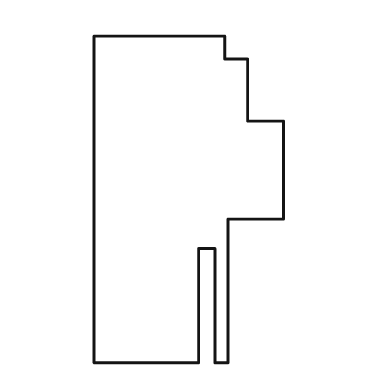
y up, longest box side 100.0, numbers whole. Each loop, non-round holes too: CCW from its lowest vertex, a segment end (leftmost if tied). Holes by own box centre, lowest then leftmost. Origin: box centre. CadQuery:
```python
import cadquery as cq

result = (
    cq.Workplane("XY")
    .moveTo(-29.0, -50.0)
    .lineTo(3.0, -50.0)
    .lineTo(3.0, -15.0)
    .lineTo(8.0, -15.0)
    .lineTo(8.0, -50.0)
    .lineTo(12.0, -50.0)
    .lineTo(12.0, -6.0)
    .lineTo(29.0, -6.0)
    .lineTo(29.0, 24.0)
    .lineTo(18.0, 24.0)
    .lineTo(18.0, 43.0)
    .lineTo(11.0, 43.0)
    .lineTo(11.0, 50.0)
    .lineTo(-29.0, 50.0)
    .close()
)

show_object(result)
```